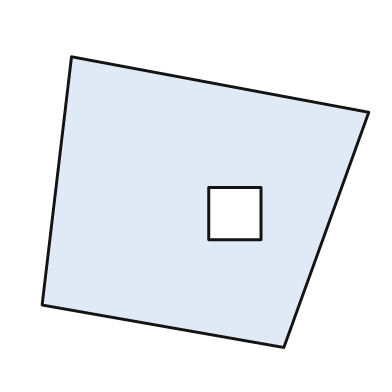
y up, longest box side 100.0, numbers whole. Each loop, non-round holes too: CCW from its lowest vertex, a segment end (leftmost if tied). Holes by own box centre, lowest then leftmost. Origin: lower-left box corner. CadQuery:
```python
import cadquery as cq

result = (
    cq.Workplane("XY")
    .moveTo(74.0, 0.0)
    .lineTo(100.0, 72.0)
    .lineTo(9.0, 89.0)
    .lineTo(0.0, 13.0)
    .close()
    .moveTo(51.0, 33.0)
    .lineTo(67.0, 33.0)
    .lineTo(67.0, 49.0)
    .lineTo(51.0, 49.0)
    .close()
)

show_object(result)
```